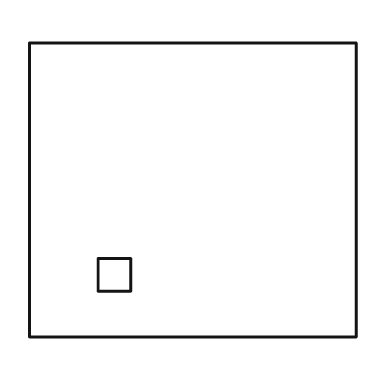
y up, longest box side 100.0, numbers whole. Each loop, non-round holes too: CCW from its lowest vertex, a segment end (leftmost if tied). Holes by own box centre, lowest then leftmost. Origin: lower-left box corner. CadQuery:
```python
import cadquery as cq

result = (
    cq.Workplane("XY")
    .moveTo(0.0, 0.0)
    .lineTo(100.0, 0.0)
    .lineTo(100.0, 90.0)
    .lineTo(0.0, 90.0)
    .close()
    .moveTo(21.0, 14.0)
    .lineTo(31.0, 14.0)
    .lineTo(31.0, 24.0)
    .lineTo(21.0, 24.0)
    .close()
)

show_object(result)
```